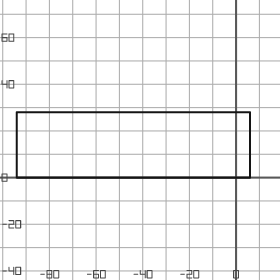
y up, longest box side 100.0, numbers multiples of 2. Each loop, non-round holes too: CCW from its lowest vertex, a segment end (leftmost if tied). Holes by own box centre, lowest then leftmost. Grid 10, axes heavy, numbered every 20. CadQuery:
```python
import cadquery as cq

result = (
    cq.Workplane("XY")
    .moveTo(-94.0, 0.0)
    .lineTo(6.0, 0.0)
    .lineTo(6.0, 28.0)
    .lineTo(-94.0, 28.0)
    .close()
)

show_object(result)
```